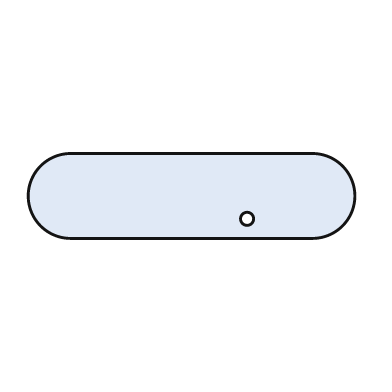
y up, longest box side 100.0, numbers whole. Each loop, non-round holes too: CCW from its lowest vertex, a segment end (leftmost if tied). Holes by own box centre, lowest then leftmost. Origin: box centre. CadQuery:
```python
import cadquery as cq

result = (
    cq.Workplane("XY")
    .moveTo(-37.0, -13.0)
    .lineTo(37.0, -13.0)
    .threePointArc((50.0, 0.0), (37.0, 13.0))
    .lineTo(-37.0, 13.0)
    .threePointArc((-50.0, 0.0), (-37.0, -13.0))
    .close()
    .moveTo(17.0, -7.0)
    .circle(2.0)
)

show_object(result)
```